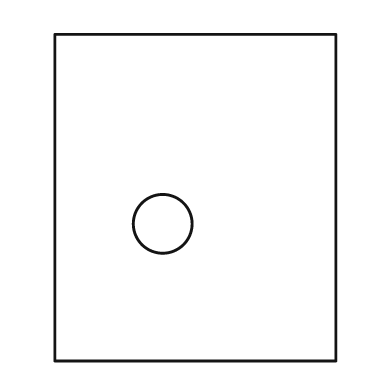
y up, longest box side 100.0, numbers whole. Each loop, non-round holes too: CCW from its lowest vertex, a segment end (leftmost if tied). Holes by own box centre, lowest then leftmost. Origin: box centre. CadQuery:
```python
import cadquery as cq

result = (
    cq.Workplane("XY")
    .moveTo(-43.0, -50.0)
    .lineTo(43.0, -50.0)
    .lineTo(43.0, 50.0)
    .lineTo(-43.0, 50.0)
    .close()
    .moveTo(-10.0, -8.0)
    .circle(9.0)
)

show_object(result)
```